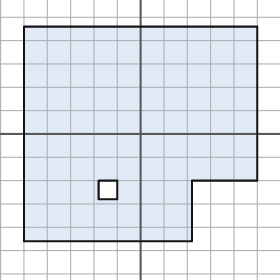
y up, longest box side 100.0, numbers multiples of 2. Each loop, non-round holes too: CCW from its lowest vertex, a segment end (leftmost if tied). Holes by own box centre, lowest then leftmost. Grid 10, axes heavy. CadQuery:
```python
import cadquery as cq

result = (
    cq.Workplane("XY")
    .moveTo(-50.0, -46.0)
    .lineTo(22.0, -46.0)
    .lineTo(22.0, -20.0)
    .lineTo(50.0, -20.0)
    .lineTo(50.0, 46.0)
    .lineTo(-50.0, 46.0)
    .close()
    .moveTo(-18.0, -28.0)
    .lineTo(-10.0, -28.0)
    .lineTo(-10.0, -20.0)
    .lineTo(-18.0, -20.0)
    .close()
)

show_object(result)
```